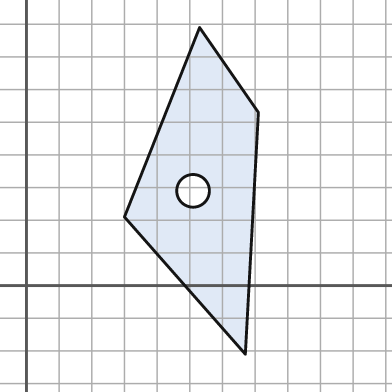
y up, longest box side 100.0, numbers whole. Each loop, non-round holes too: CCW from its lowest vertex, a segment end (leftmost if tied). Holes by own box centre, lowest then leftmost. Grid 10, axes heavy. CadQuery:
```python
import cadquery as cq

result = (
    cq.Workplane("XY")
    .moveTo(67.0, -21.0)
    .lineTo(71.0, 53.0)
    .lineTo(53.0, 79.0)
    .lineTo(30.0, 21.0)
    .close()
    .moveTo(51.0, 29.0)
    .circle(5.0)
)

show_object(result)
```